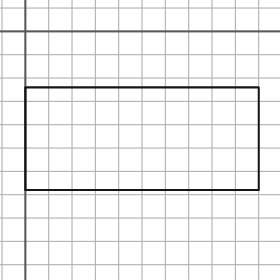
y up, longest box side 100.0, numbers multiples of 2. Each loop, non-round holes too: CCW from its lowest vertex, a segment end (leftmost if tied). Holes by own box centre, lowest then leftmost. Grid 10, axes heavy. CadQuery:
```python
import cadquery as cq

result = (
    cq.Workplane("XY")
    .moveTo(0.0, -68.0)
    .lineTo(100.0, -68.0)
    .lineTo(100.0, -24.0)
    .lineTo(0.0, -24.0)
    .close()
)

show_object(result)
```